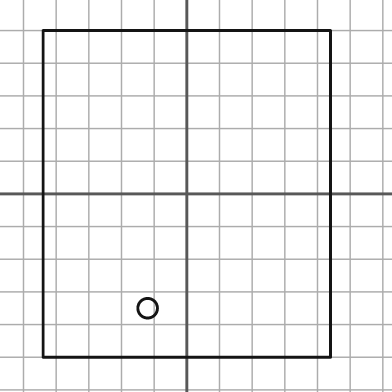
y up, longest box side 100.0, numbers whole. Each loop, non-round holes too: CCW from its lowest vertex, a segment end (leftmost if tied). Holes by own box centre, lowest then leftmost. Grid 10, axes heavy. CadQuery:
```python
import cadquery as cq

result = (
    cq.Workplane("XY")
    .moveTo(-44.0, -50.0)
    .lineTo(44.0, -50.0)
    .lineTo(44.0, 50.0)
    .lineTo(-44.0, 50.0)
    .close()
    .moveTo(-12.0, -35.0)
    .circle(3.0)
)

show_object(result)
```